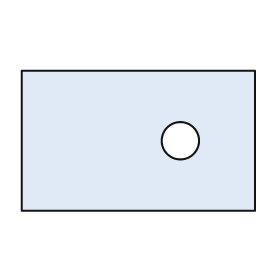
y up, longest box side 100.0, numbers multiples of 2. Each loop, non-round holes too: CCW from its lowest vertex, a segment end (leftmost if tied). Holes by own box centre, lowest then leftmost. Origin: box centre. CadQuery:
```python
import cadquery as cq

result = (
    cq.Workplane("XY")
    .moveTo(-50.0, -30.0)
    .lineTo(50.0, -30.0)
    .lineTo(50.0, 30.0)
    .lineTo(-50.0, 30.0)
    .close()
    .moveTo(18.0, 0.0)
    .circle(8.0)
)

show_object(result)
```